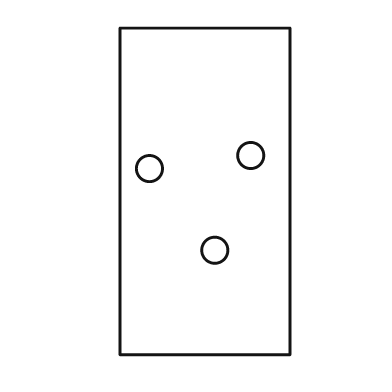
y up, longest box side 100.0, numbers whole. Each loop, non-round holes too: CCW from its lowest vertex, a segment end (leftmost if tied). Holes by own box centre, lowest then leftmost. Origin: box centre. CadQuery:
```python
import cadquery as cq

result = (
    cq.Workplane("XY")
    .moveTo(-26.0, -50.0)
    .lineTo(26.0, -50.0)
    .lineTo(26.0, 50.0)
    .lineTo(-26.0, 50.0)
    .close()
    .moveTo(3.0, -18.0)
    .circle(4.0)
    .moveTo(-17.0, 7.0)
    .circle(4.0)
    .moveTo(14.0, 11.0)
    .circle(4.0)
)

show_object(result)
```